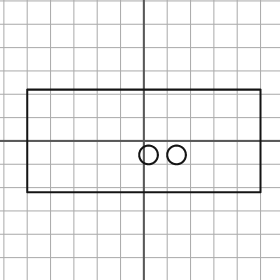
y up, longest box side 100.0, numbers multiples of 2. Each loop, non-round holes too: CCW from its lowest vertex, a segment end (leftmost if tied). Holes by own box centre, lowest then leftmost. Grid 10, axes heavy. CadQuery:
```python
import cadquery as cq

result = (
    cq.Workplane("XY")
    .moveTo(-50.0, -22.0)
    .lineTo(50.0, -22.0)
    .lineTo(50.0, 22.0)
    .lineTo(-50.0, 22.0)
    .close()
    .moveTo(2.0, -6.0)
    .circle(4.0)
    .moveTo(14.0, -6.0)
    .circle(4.0)
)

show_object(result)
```